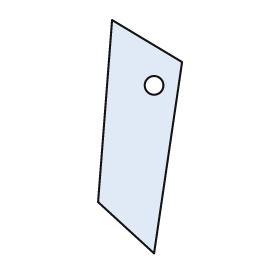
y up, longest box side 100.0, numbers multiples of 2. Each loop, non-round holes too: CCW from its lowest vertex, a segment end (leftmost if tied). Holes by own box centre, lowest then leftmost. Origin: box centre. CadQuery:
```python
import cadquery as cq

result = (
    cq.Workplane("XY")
    .moveTo(6.0, -50.0)
    .lineTo(18.0, 32.0)
    .lineTo(-12.0, 50.0)
    .lineTo(-18.0, -28.0)
    .close()
    .moveTo(6.0, 22.0)
    .circle(4.0)
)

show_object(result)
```